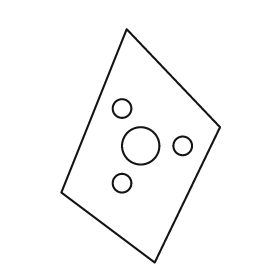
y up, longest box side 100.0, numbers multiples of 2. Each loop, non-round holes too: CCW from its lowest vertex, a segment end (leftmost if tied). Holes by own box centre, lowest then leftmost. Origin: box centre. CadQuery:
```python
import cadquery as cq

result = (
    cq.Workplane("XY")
    .moveTo(6.0, -50.0)
    .lineTo(34.0, 8.0)
    .lineTo(-6.0, 50.0)
    .lineTo(-34.0, -20.0)
    .close()
    .moveTo(-8.0, -16.0)
    .circle(4.0)
    .moveTo(0.0, 0.0)
    .circle(8.0)
    .moveTo(18.0, 0.0)
    .circle(4.0)
    .moveTo(-8.0, 16.0)
    .circle(4.0)
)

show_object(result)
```